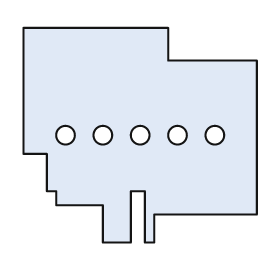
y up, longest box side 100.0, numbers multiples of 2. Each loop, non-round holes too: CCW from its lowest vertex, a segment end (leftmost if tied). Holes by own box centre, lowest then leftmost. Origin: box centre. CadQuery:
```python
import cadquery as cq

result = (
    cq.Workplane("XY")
    .moveTo(-16.0, -46.0)
    .lineTo(-4.0, -46.0)
    .lineTo(-4.0, -24.0)
    .lineTo(2.0, -24.0)
    .lineTo(2.0, -46.0)
    .lineTo(6.0, -46.0)
    .lineTo(6.0, -34.0)
    .lineTo(50.0, -34.0)
    .lineTo(50.0, 32.0)
    .lineTo(12.0, 32.0)
    .lineTo(12.0, 46.0)
    .lineTo(-50.0, 46.0)
    .lineTo(-50.0, -8.0)
    .lineTo(-40.0, -8.0)
    .lineTo(-40.0, -24.0)
    .lineTo(-36.0, -24.0)
    .lineTo(-36.0, -30.0)
    .lineTo(-16.0, -30.0)
    .close()
    .moveTo(-32.0, 0.0)
    .circle(4.0)
    .moveTo(-16.0, 0.0)
    .circle(4.0)
    .moveTo(0.0, 0.0)
    .circle(4.0)
    .moveTo(16.0, 0.0)
    .circle(4.0)
    .moveTo(32.0, 0.0)
    .circle(4.0)
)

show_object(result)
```